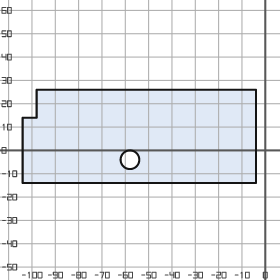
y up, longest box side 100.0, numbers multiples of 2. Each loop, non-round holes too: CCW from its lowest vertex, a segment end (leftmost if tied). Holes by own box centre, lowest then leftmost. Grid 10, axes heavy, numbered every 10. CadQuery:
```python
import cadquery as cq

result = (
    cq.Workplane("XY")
    .moveTo(-104.0, -14.0)
    .lineTo(-4.0, -14.0)
    .lineTo(-4.0, 26.0)
    .lineTo(-98.0, 26.0)
    .lineTo(-98.0, 14.0)
    .lineTo(-104.0, 14.0)
    .close()
    .moveTo(-58.0, -4.0)
    .circle(4.0)
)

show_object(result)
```